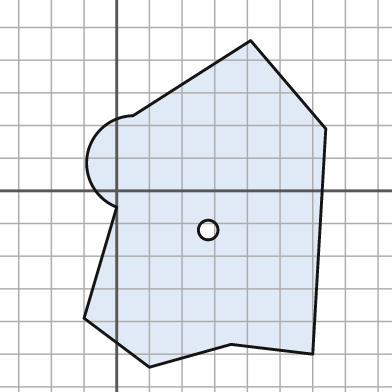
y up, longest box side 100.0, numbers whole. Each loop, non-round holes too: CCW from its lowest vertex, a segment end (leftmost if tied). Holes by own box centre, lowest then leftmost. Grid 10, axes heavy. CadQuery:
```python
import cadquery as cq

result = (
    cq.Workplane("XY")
    .moveTo(10.0, -54.0)
    .lineTo(35.0, -47.0)
    .lineTo(60.0, -50.0)
    .lineTo(64.0, 19.0)
    .lineTo(41.0, 46.0)
    .lineTo(5.0, 23.0)
    .threePointArc((-9.0, 11.0), (0.0, -5.0))
    .lineTo(-10.0, -39.0)
    .close()
    .moveTo(28.0, -12.0)
    .circle(3.0)
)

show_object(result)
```